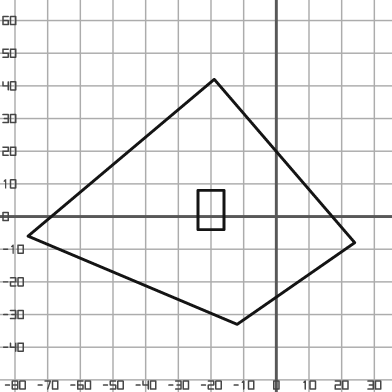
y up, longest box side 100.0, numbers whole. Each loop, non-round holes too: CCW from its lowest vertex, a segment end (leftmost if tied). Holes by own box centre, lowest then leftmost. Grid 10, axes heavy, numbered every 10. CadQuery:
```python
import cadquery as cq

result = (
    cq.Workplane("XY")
    .moveTo(-12.0, -33.0)
    .lineTo(24.0, -8.0)
    .lineTo(-19.0, 42.0)
    .lineTo(-76.0, -6.0)
    .close()
    .moveTo(-24.0, -4.0)
    .lineTo(-16.0, -4.0)
    .lineTo(-16.0, 8.0)
    .lineTo(-24.0, 8.0)
    .close()
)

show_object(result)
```